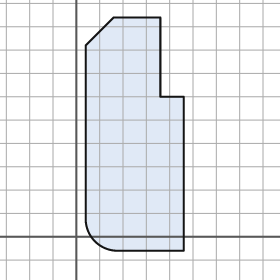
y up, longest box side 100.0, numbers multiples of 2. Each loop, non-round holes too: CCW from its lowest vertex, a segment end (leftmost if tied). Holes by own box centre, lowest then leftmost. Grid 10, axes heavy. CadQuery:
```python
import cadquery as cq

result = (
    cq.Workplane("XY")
    .moveTo(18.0, -6.0)
    .lineTo(46.0, -6.0)
    .lineTo(46.0, 60.0)
    .lineTo(36.0, 60.0)
    .lineTo(36.0, 94.0)
    .lineTo(16.0, 94.0)
    .lineTo(4.0, 82.0)
    .lineTo(4.0, 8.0)
    .threePointArc((8.0, -2.0), (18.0, -6.0))
    .close()
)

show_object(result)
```